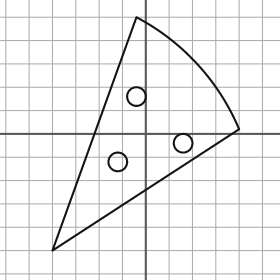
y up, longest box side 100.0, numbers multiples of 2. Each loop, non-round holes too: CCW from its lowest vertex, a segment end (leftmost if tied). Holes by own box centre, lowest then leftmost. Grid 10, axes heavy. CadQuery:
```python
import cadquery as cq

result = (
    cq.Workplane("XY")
    .moveTo(-40.0, -50.0)
    .lineTo(40.0, 2.0)
    .threePointArc((22.0, 30.0), (-4.0, 50.0))
    .close()
    .moveTo(-12.0, -12.0)
    .circle(4.0)
    .moveTo(16.0, -4.0)
    .circle(4.0)
    .moveTo(-4.0, 16.0)
    .circle(4.0)
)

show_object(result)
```